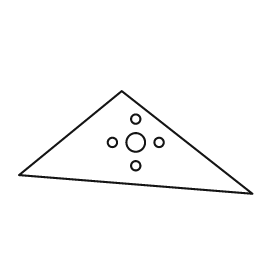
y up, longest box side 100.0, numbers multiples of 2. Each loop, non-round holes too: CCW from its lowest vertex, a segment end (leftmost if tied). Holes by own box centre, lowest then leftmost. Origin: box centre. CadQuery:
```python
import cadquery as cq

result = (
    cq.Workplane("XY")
    .moveTo(50.0, -22.0)
    .lineTo(-6.0, 22.0)
    .lineTo(-50.0, -14.0)
    .close()
    .moveTo(0.0, -10.0)
    .circle(2.0)
    .moveTo(-10.0, 0.0)
    .circle(2.0)
    .moveTo(0.0, 0.0)
    .circle(4.0)
    .moveTo(10.0, 0.0)
    .circle(2.0)
    .moveTo(0.0, 10.0)
    .circle(2.0)
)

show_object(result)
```